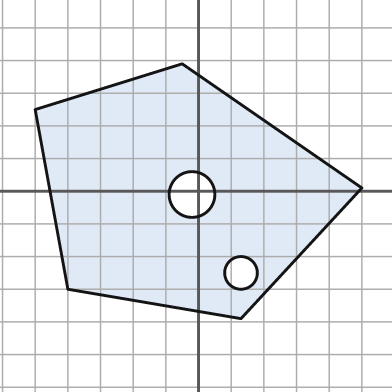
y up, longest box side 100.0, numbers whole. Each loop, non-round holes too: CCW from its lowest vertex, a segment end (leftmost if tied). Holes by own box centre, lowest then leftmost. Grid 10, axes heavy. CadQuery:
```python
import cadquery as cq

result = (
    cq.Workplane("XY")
    .moveTo(13.0, -39.0)
    .lineTo(50.0, 1.0)
    .lineTo(-5.0, 39.0)
    .lineTo(-50.0, 25.0)
    .lineTo(-40.0, -30.0)
    .close()
    .moveTo(13.0, -25.0)
    .circle(5.0)
    .moveTo(-2.0, -1.0)
    .circle(7.0)
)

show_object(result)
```